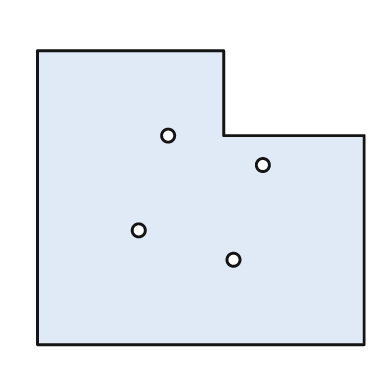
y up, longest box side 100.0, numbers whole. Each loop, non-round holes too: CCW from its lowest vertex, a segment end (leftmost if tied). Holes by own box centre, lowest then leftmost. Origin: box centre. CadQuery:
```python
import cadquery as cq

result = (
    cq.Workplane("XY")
    .moveTo(-50.0, -45.0)
    .lineTo(50.0, -45.0)
    .lineTo(50.0, 19.0)
    .lineTo(7.0, 19.0)
    .lineTo(7.0, 45.0)
    .lineTo(-50.0, 45.0)
    .close()
    .moveTo(10.0, -19.0)
    .circle(2.0)
    .moveTo(-19.0, -10.0)
    .circle(2.0)
    .moveTo(19.0, 10.0)
    .circle(2.0)
    .moveTo(-10.0, 19.0)
    .circle(2.0)
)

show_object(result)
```